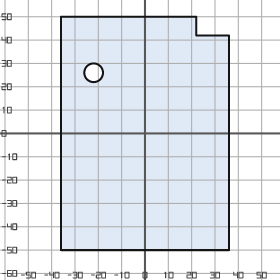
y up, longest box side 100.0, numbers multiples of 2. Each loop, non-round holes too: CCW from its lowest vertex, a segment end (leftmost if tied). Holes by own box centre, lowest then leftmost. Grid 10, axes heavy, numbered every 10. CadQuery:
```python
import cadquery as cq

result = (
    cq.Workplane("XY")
    .moveTo(-36.0, -50.0)
    .lineTo(36.0, -50.0)
    .lineTo(36.0, 42.0)
    .lineTo(22.0, 42.0)
    .lineTo(22.0, 50.0)
    .lineTo(-36.0, 50.0)
    .close()
    .moveTo(-22.0, 26.0)
    .circle(4.0)
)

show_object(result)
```